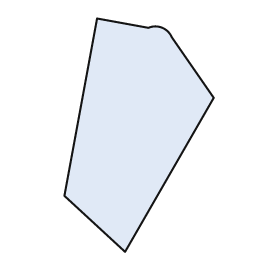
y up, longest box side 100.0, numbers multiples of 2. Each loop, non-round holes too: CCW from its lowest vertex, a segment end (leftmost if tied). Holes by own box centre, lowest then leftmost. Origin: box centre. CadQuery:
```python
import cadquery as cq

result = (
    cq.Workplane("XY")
    .moveTo(-6.0, -50.0)
    .lineTo(32.0, 16.0)
    .lineTo(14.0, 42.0)
    .threePointArc((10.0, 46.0), (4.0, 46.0))
    .lineTo(-18.0, 50.0)
    .lineTo(-32.0, -26.0)
    .close()
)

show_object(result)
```